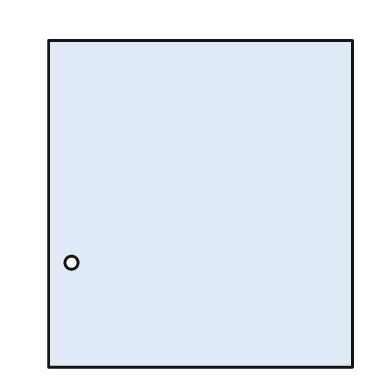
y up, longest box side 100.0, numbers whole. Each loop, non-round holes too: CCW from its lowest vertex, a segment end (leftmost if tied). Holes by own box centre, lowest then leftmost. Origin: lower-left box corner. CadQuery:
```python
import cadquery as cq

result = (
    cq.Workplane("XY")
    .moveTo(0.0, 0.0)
    .lineTo(93.0, 0.0)
    .lineTo(93.0, 100.0)
    .lineTo(0.0, 100.0)
    .close()
    .moveTo(7.0, 32.0)
    .circle(2.0)
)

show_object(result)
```